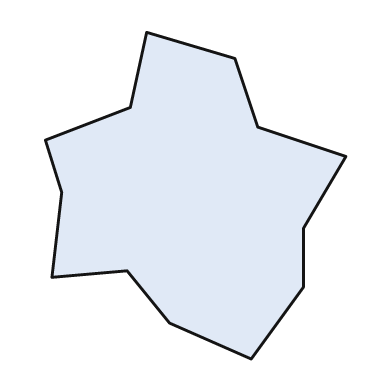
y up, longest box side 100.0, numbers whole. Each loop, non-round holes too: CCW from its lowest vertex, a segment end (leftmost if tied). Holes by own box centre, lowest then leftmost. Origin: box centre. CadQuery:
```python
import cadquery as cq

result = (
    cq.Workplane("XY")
    .moveTo(17.0, -50.0)
    .lineTo(33.0, -28.0)
    .lineTo(33.0, -10.0)
    .lineTo(46.0, 12.0)
    .lineTo(19.0, 21.0)
    .lineTo(12.0, 42.0)
    .lineTo(-15.0, 50.0)
    .lineTo(-20.0, 27.0)
    .lineTo(-46.0, 17.0)
    .lineTo(-41.0, 1.0)
    .lineTo(-44.0, -25.0)
    .lineTo(-21.0, -23.0)
    .lineTo(-8.0, -39.0)
    .close()
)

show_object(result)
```